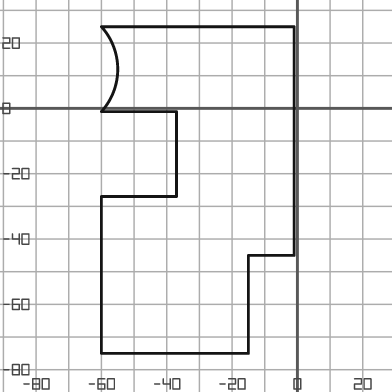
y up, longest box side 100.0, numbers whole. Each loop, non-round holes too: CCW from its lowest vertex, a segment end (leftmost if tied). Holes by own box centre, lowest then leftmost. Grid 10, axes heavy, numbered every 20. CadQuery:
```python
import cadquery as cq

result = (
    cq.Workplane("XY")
    .moveTo(-60.0, -75.0)
    .lineTo(-15.0, -75.0)
    .lineTo(-15.0, -45.0)
    .lineTo(-1.0, -45.0)
    .lineTo(-1.0, 25.0)
    .lineTo(-60.0, 25.0)
    .threePointArc((-55.0, 12.0), (-60.0, -1.0))
    .lineTo(-37.0, -1.0)
    .lineTo(-37.0, -27.0)
    .lineTo(-60.0, -27.0)
    .close()
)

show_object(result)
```